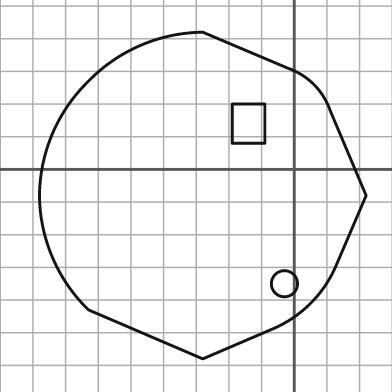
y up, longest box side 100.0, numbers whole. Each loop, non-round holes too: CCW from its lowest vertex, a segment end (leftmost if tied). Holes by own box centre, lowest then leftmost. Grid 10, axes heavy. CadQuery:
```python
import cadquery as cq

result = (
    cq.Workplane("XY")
    .moveTo(-28.0, -58.0)
    .lineTo(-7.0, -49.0)
    .threePointArc((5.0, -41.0), (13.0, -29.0))
    .lineTo(22.0, -8.0)
    .lineTo(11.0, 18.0)
    .threePointArc((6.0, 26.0), (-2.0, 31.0))
    .lineTo(-28.0, 42.0)
    .threePointArc((-47.0, 38.0), (-63.0, 27.0))
    .threePointArc((-74.0, 11.0), (-78.0, -8.0))
    .threePointArc((-74.0, -27.0), (-63.0, -43.0))
    .close()
    .moveTo(-3.0, -35.0)
    .circle(4.0)
    .moveTo(-19.0, 8.0)
    .lineTo(-9.0, 8.0)
    .lineTo(-9.0, 20.0)
    .lineTo(-19.0, 20.0)
    .close()
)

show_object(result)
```